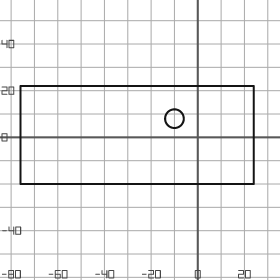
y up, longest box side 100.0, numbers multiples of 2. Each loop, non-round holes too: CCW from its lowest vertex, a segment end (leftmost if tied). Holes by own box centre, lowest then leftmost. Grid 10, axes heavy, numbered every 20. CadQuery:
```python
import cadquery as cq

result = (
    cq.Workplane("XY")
    .moveTo(-76.0, -20.0)
    .lineTo(24.0, -20.0)
    .lineTo(24.0, 22.0)
    .lineTo(-76.0, 22.0)
    .close()
    .moveTo(-10.0, 8.0)
    .circle(4.0)
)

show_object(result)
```